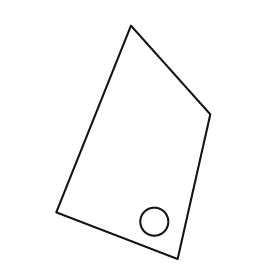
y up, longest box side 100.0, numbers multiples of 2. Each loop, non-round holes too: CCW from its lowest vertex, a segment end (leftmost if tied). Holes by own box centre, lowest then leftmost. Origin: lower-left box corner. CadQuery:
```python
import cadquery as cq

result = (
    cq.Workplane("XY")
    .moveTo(52.0, 0.0)
    .lineTo(66.0, 62.0)
    .lineTo(32.0, 100.0)
    .lineTo(0.0, 20.0)
    .close()
    .moveTo(42.0, 16.0)
    .circle(6.0)
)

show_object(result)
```